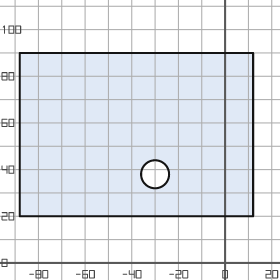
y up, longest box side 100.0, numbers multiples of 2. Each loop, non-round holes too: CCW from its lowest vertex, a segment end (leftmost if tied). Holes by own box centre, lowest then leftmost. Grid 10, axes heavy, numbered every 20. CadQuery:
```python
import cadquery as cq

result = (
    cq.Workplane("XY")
    .moveTo(-88.0, 20.0)
    .lineTo(12.0, 20.0)
    .lineTo(12.0, 90.0)
    .lineTo(-88.0, 90.0)
    .close()
    .moveTo(-30.0, 38.0)
    .circle(6.0)
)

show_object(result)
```